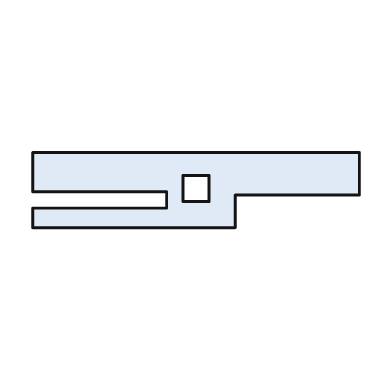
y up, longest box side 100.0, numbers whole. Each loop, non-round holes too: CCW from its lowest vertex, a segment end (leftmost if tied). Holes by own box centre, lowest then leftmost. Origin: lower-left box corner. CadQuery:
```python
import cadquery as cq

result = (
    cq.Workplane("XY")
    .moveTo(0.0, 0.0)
    .lineTo(62.0, 0.0)
    .lineTo(62.0, 10.0)
    .lineTo(100.0, 10.0)
    .lineTo(100.0, 23.0)
    .lineTo(0.0, 23.0)
    .lineTo(0.0, 11.0)
    .lineTo(41.0, 11.0)
    .lineTo(41.0, 6.0)
    .lineTo(0.0, 6.0)
    .close()
    .moveTo(46.0, 8.0)
    .lineTo(54.0, 8.0)
    .lineTo(54.0, 16.0)
    .lineTo(46.0, 16.0)
    .close()
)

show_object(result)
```